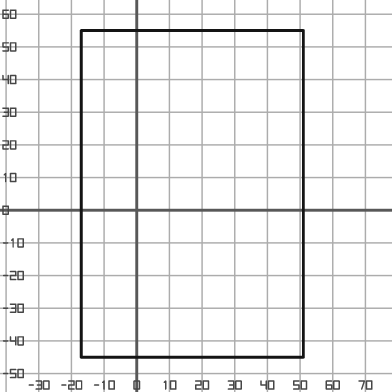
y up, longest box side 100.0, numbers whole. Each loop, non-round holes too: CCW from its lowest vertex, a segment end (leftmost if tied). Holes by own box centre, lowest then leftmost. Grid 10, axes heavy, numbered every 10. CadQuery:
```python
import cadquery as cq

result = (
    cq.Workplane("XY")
    .moveTo(-17.0, -45.0)
    .lineTo(51.0, -45.0)
    .lineTo(51.0, 55.0)
    .lineTo(-17.0, 55.0)
    .close()
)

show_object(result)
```